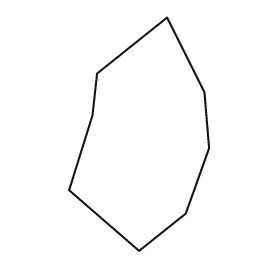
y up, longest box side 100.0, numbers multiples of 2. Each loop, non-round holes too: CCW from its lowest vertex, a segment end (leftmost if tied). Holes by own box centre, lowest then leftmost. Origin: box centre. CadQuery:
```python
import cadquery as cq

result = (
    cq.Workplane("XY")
    .moveTo(0.0, -50.0)
    .lineTo(20.0, -34.0)
    .lineTo(30.0, -6.0)
    .lineTo(28.0, 18.0)
    .lineTo(12.0, 50.0)
    .lineTo(-18.0, 26.0)
    .lineTo(-20.0, 8.0)
    .lineTo(-30.0, -24.0)
    .close()
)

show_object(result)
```